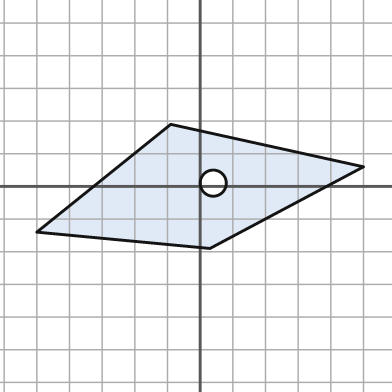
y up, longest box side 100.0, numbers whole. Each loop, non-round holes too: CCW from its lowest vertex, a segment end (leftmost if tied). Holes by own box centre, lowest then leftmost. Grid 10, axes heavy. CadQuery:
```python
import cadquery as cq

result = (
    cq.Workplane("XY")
    .moveTo(3.0, -19.0)
    .lineTo(50.0, 6.0)
    .lineTo(-9.0, 19.0)
    .lineTo(-50.0, -14.0)
    .close()
    .moveTo(4.0, 1.0)
    .circle(4.0)
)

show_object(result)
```